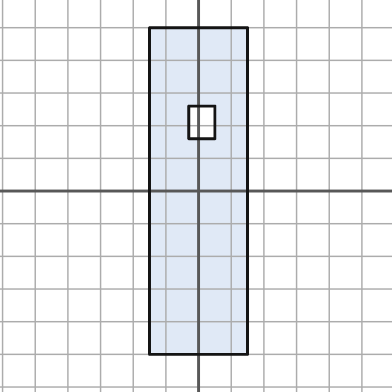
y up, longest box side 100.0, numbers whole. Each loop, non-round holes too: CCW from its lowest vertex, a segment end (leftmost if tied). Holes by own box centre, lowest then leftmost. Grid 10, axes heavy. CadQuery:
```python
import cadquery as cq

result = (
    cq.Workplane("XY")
    .moveTo(-15.0, -50.0)
    .lineTo(15.0, -50.0)
    .lineTo(15.0, 50.0)
    .lineTo(-15.0, 50.0)
    .close()
    .moveTo(-3.0, 16.0)
    .lineTo(5.0, 16.0)
    .lineTo(5.0, 26.0)
    .lineTo(-3.0, 26.0)
    .close()
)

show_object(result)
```